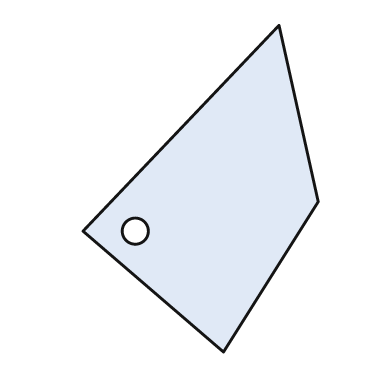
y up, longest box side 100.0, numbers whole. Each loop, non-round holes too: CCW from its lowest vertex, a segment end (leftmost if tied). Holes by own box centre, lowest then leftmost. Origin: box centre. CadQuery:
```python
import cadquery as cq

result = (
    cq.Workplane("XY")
    .moveTo(7.0, -50.0)
    .lineTo(36.0, -4.0)
    .lineTo(24.0, 50.0)
    .lineTo(-36.0, -13.0)
    .close()
    .moveTo(-20.0, -13.0)
    .circle(4.0)
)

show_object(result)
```